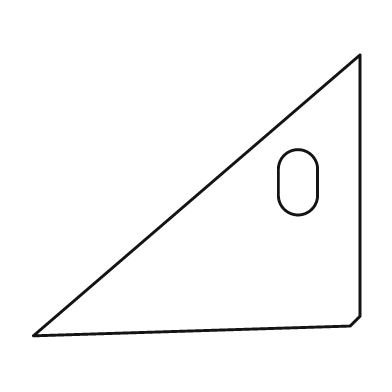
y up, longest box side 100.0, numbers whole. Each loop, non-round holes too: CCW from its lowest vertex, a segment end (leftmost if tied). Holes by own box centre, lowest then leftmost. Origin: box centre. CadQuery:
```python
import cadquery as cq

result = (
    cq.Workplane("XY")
    .moveTo(-50.0, -43.0)
    .lineTo(47.0, -40.0)
    .lineTo(50.0, -37.0)
    .lineTo(50.0, 43.0)
    .close()
    .moveTo(25.0, 0.0)
    .threePointArc((31.0, -6.0), (37.0, 0.0))
    .lineTo(37.0, 8.0)
    .threePointArc((31.0, 14.0), (25.0, 8.0))
    .close()
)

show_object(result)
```